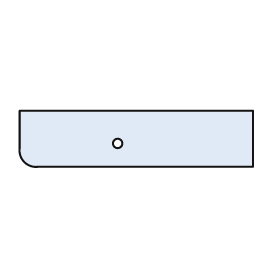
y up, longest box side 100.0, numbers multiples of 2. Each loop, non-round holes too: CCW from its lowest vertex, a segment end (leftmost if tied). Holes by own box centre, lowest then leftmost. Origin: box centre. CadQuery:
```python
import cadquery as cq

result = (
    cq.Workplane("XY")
    .moveTo(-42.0, -12.0)
    .lineTo(50.0, -12.0)
    .lineTo(50.0, 12.0)
    .lineTo(-50.0, 12.0)
    .lineTo(-50.0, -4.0)
    .threePointArc((-48.0, -10.0), (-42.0, -12.0))
    .close()
    .moveTo(-8.0, -2.0)
    .circle(2.0)
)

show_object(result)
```